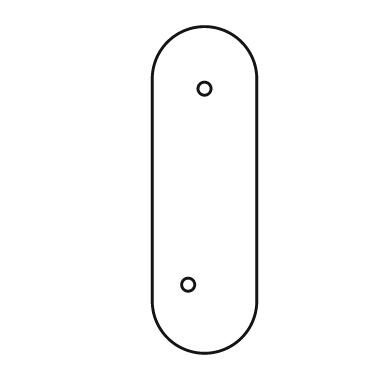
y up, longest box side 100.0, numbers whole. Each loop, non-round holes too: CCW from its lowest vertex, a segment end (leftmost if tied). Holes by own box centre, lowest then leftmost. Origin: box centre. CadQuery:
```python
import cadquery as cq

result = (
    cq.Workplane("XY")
    .moveTo(-16.0, -34.0)
    .threePointArc((0.0, -50.0), (16.0, -34.0))
    .lineTo(16.0, 34.0)
    .threePointArc((0.0, 50.0), (-16.0, 34.0))
    .close()
    .moveTo(-5.0, -29.0)
    .circle(2.0)
    .moveTo(0.0, 31.0)
    .circle(2.0)
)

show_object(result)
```